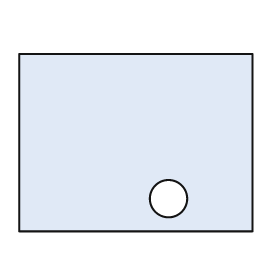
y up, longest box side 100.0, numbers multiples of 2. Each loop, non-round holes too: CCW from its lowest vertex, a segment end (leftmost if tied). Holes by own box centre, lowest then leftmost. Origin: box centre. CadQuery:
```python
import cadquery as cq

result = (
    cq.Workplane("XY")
    .moveTo(-50.0, -38.0)
    .lineTo(50.0, -38.0)
    .lineTo(50.0, 38.0)
    .lineTo(-50.0, 38.0)
    .close()
    .moveTo(14.0, -24.0)
    .circle(8.0)
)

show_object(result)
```